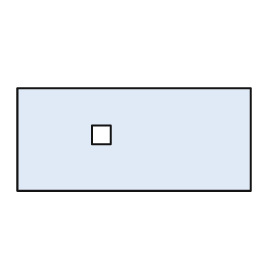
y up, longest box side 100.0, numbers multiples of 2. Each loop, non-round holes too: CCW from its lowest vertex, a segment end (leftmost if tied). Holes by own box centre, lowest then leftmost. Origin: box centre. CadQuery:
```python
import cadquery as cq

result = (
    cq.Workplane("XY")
    .moveTo(-50.0, -22.0)
    .lineTo(50.0, -22.0)
    .lineTo(50.0, 22.0)
    .lineTo(-50.0, 22.0)
    .close()
    .moveTo(-18.0, -2.0)
    .lineTo(-10.0, -2.0)
    .lineTo(-10.0, 6.0)
    .lineTo(-18.0, 6.0)
    .close()
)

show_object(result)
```